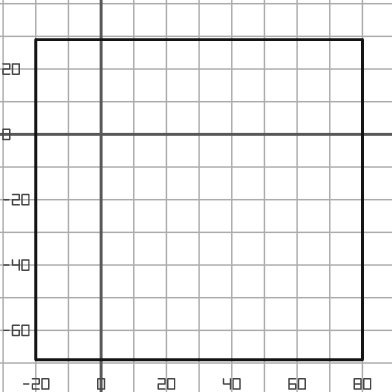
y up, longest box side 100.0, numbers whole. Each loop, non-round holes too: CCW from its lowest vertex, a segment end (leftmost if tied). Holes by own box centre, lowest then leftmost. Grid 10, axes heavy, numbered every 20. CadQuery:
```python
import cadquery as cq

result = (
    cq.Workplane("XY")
    .moveTo(-20.0, -69.0)
    .lineTo(80.0, -69.0)
    .lineTo(80.0, 29.0)
    .lineTo(-20.0, 29.0)
    .close()
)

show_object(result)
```